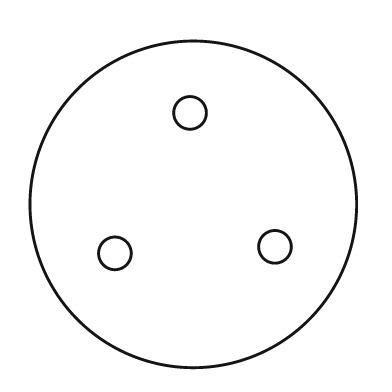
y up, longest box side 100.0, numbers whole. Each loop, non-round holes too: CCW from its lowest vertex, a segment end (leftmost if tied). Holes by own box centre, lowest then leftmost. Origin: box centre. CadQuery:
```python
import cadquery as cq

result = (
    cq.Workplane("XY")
    .moveTo(0.0, 0.0)
    .circle(50.0)
    .moveTo(-24.0, -15.0)
    .circle(5.0)
    .moveTo(25.0, -13.0)
    .circle(5.0)
    .moveTo(-1.0, 28.0)
    .circle(5.0)
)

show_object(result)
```